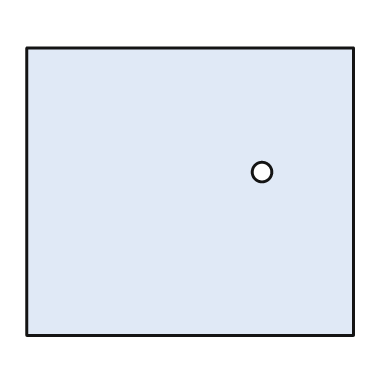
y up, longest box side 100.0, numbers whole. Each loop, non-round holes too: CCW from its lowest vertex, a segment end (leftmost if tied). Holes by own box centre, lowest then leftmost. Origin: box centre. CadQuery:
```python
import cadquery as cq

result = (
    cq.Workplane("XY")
    .moveTo(-50.0, -44.0)
    .lineTo(50.0, -44.0)
    .lineTo(50.0, 44.0)
    .lineTo(-50.0, 44.0)
    .close()
    .moveTo(22.0, 6.0)
    .circle(3.0)
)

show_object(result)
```